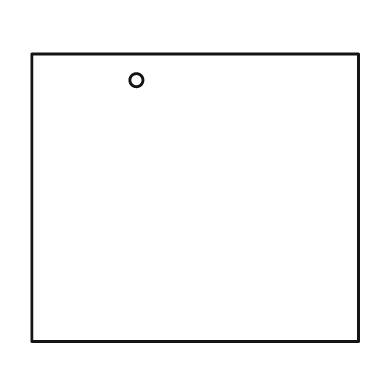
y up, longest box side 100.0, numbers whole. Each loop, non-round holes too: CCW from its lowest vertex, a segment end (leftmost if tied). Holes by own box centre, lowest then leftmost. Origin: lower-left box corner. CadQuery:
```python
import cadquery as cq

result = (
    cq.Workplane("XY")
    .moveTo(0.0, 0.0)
    .lineTo(100.0, 0.0)
    .lineTo(100.0, 88.0)
    .lineTo(0.0, 88.0)
    .close()
    .moveTo(32.0, 80.0)
    .circle(2.0)
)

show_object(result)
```